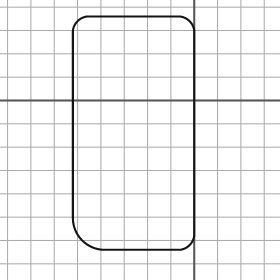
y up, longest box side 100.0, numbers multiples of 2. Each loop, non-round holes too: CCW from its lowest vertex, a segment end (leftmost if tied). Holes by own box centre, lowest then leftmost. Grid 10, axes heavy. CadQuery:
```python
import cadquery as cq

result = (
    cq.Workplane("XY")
    .moveTo(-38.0, -64.0)
    .lineTo(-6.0, -64.0)
    .threePointArc((-2.0, -62.0), (0.0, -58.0))
    .lineTo(0.0, 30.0)
    .threePointArc((-2.0, 34.0), (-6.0, 36.0))
    .lineTo(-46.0, 36.0)
    .threePointArc((-50.0, 34.0), (-52.0, 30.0))
    .lineTo(-52.0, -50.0)
    .threePointArc((-48.0, -60.0), (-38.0, -64.0))
    .close()
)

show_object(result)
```